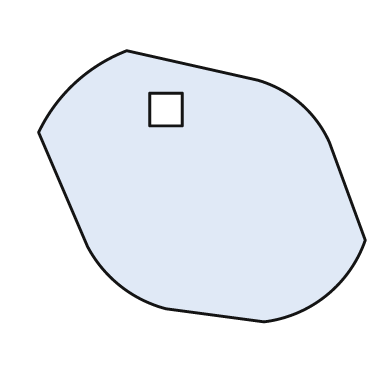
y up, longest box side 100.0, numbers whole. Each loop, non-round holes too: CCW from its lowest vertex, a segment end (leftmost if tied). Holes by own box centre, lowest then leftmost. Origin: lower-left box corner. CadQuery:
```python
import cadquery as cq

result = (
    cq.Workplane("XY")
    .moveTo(69.0, 0.0)
    .threePointArc((88.0, 8.0), (100.0, 25.0))
    .lineTo(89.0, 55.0)
    .threePointArc((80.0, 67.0), (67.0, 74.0))
    .lineTo(27.0, 83.0)
    .threePointArc((11.0, 73.0), (0.0, 58.0))
    .lineTo(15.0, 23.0)
    .threePointArc((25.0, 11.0), (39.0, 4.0))
    .close()
    .moveTo(34.0, 60.0)
    .lineTo(44.0, 60.0)
    .lineTo(44.0, 70.0)
    .lineTo(34.0, 70.0)
    .close()
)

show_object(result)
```